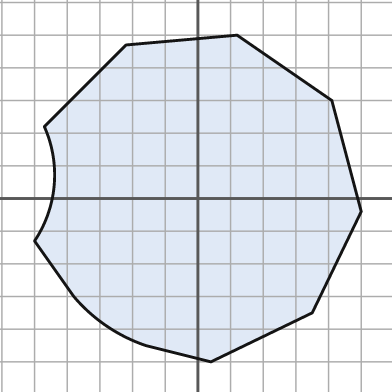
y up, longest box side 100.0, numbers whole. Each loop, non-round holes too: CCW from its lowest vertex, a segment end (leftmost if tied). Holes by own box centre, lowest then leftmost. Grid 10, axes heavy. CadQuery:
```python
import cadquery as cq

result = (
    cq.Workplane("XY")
    .moveTo(4.0, -50.0)
    .lineTo(35.0, -35.0)
    .lineTo(50.0, -4.0)
    .lineTo(41.0, 30.0)
    .lineTo(12.0, 50.0)
    .lineTo(-22.0, 47.0)
    .lineTo(-47.0, 22.0)
    .threePointArc((-44.0, 4.0), (-50.0, -13.0))
    .lineTo(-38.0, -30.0)
    .threePointArc((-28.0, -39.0), (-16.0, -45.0))
    .close()
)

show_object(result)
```